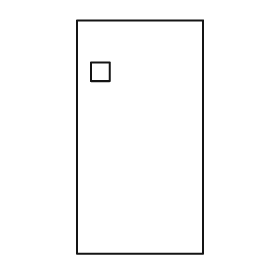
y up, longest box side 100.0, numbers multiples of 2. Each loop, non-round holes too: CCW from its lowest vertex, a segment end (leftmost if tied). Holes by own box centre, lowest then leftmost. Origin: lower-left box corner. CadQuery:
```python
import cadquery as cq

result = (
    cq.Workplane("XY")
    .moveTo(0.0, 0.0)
    .lineTo(54.0, 0.0)
    .lineTo(54.0, 100.0)
    .lineTo(0.0, 100.0)
    .close()
    .moveTo(6.0, 74.0)
    .lineTo(14.0, 74.0)
    .lineTo(14.0, 82.0)
    .lineTo(6.0, 82.0)
    .close()
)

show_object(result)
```